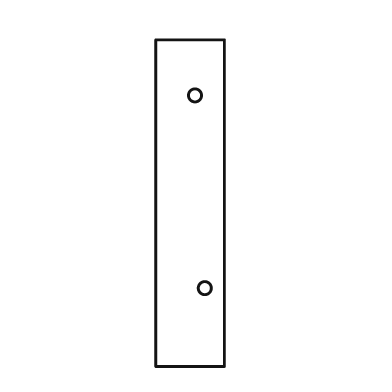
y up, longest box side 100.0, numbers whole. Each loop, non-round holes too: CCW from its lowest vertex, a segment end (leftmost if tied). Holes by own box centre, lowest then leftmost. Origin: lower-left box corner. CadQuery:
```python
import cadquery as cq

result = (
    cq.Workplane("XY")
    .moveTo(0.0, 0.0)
    .lineTo(21.0, 0.0)
    .lineTo(21.0, 100.0)
    .lineTo(0.0, 100.0)
    .close()
    .moveTo(15.0, 24.0)
    .circle(2.0)
    .moveTo(12.0, 83.0)
    .circle(2.0)
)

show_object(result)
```